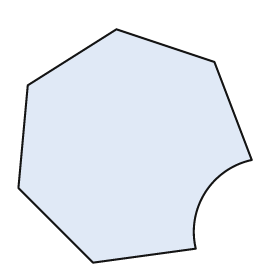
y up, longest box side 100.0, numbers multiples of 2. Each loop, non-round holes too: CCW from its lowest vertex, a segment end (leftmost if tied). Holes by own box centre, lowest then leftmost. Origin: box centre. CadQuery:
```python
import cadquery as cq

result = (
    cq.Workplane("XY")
    .moveTo(-18.0, -50.0)
    .lineTo(26.0, -44.0)
    .threePointArc((30.0, -20.0), (50.0, -6.0))
    .lineTo(34.0, 36.0)
    .lineTo(-8.0, 50.0)
    .lineTo(-46.0, 26.0)
    .lineTo(-50.0, -18.0)
    .close()
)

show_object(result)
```